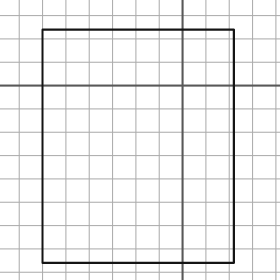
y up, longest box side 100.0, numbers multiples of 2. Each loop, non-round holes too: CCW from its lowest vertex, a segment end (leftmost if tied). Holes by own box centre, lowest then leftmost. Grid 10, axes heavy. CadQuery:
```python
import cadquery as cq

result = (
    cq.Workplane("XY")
    .moveTo(-60.0, -76.0)
    .lineTo(22.0, -76.0)
    .lineTo(22.0, 24.0)
    .lineTo(-60.0, 24.0)
    .close()
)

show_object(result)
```